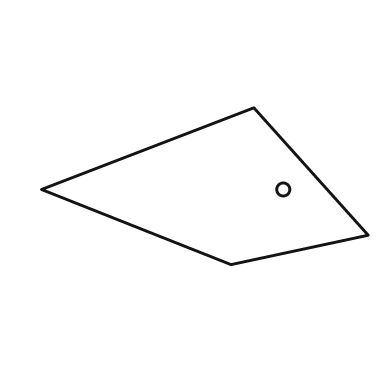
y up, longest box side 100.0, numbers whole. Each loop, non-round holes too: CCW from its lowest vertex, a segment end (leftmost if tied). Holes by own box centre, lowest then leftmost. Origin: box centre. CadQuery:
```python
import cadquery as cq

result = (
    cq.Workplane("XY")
    .moveTo(8.0, -24.0)
    .lineTo(50.0, -15.0)
    .lineTo(15.0, 24.0)
    .lineTo(-50.0, -1.0)
    .close()
    .moveTo(24.0, -1.0)
    .circle(2.0)
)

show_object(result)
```